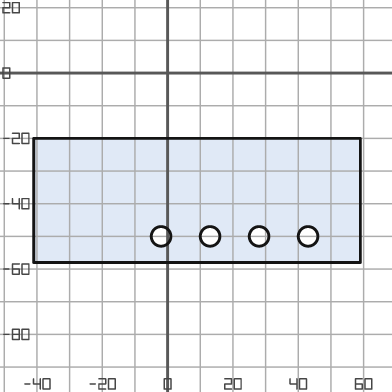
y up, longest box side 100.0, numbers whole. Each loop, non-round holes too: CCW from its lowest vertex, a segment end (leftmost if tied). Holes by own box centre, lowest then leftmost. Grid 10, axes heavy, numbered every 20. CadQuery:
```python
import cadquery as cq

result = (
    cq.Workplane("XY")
    .moveTo(-41.0, -58.0)
    .lineTo(59.0, -58.0)
    .lineTo(59.0, -20.0)
    .lineTo(-41.0, -20.0)
    .close()
    .moveTo(-2.0, -50.0)
    .circle(3.0)
    .moveTo(13.0, -50.0)
    .circle(3.0)
    .moveTo(28.0, -50.0)
    .circle(3.0)
    .moveTo(43.0, -50.0)
    .circle(3.0)
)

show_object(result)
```